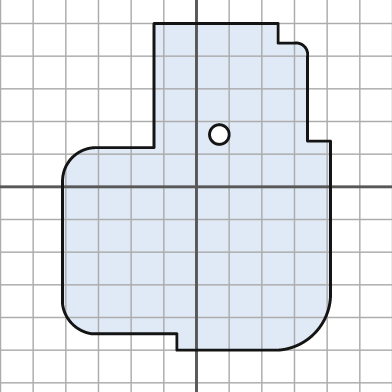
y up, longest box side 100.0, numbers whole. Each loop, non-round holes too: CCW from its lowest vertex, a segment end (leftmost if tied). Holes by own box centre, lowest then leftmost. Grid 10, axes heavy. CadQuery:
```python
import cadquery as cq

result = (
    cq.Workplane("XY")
    .moveTo(-6.0, -50.0)
    .lineTo(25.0, -50.0)
    .threePointArc((36.0, -45.0), (41.0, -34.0))
    .lineTo(41.0, 14.0)
    .lineTo(34.0, 14.0)
    .lineTo(34.0, 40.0)
    .threePointArc((33.0, 43.0), (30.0, 44.0))
    .lineTo(25.0, 44.0)
    .lineTo(25.0, 50.0)
    .lineTo(-13.0, 50.0)
    .lineTo(-13.0, 12.0)
    .lineTo(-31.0, 12.0)
    .threePointArc((-38.0, 9.0), (-41.0, 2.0))
    .lineTo(-41.0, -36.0)
    .threePointArc((-38.0, -42.0), (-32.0, -45.0))
    .lineTo(-6.0, -45.0)
    .close()
    .moveTo(7.0, 16.0)
    .circle(3.0)
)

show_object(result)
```